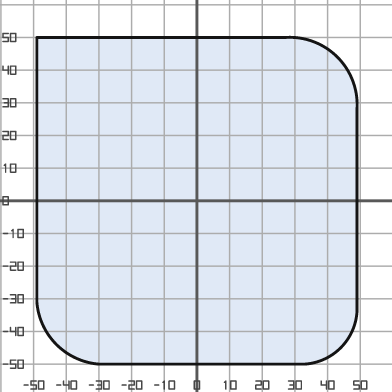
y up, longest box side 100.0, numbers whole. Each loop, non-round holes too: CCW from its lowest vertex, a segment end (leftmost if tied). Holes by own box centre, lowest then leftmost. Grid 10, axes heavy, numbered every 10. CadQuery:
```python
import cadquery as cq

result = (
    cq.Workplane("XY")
    .moveTo(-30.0, -50.0)
    .lineTo(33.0, -50.0)
    .threePointArc((44.0, -45.0), (49.0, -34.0))
    .lineTo(49.0, 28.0)
    .threePointArc((43.0, 44.0), (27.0, 50.0))
    .lineTo(-49.0, 50.0)
    .lineTo(-49.0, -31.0)
    .threePointArc((-43.0, -44.0), (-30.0, -50.0))
    .close()
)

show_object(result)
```